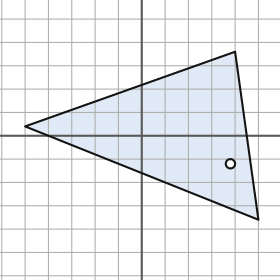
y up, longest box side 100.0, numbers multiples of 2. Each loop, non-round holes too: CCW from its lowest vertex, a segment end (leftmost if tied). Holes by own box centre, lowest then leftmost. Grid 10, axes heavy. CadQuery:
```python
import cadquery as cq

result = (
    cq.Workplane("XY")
    .moveTo(50.0, -36.0)
    .lineTo(40.0, 36.0)
    .lineTo(-50.0, 4.0)
    .close()
    .moveTo(38.0, -12.0)
    .circle(2.0)
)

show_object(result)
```